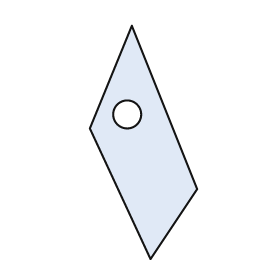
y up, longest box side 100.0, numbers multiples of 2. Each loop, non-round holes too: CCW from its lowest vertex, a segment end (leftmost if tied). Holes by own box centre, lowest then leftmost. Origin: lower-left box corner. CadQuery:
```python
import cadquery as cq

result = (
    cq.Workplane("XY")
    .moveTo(26.0, 0.0)
    .lineTo(46.0, 30.0)
    .lineTo(18.0, 100.0)
    .lineTo(0.0, 56.0)
    .close()
    .moveTo(16.0, 62.0)
    .circle(6.0)
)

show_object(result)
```